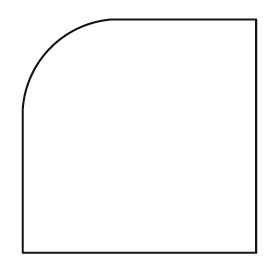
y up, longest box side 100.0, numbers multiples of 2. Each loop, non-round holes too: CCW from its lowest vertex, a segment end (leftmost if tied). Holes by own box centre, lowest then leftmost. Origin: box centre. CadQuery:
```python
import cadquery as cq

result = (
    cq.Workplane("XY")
    .moveTo(-50.0, -50.0)
    .lineTo(50.0, -50.0)
    .lineTo(50.0, 50.0)
    .lineTo(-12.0, 50.0)
    .threePointArc((-38.0, 38.0), (-50.0, 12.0))
    .close()
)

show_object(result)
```